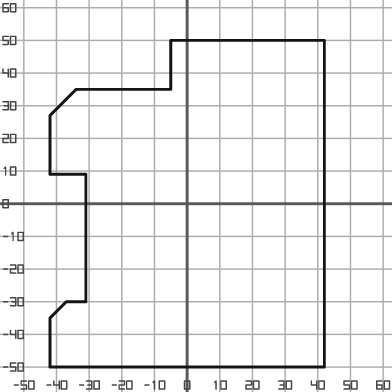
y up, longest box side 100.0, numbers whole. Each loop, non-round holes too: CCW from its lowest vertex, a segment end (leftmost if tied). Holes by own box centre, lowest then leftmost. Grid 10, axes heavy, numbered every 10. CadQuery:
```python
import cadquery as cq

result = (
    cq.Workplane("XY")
    .moveTo(-42.0, -50.0)
    .lineTo(42.0, -50.0)
    .lineTo(42.0, 50.0)
    .lineTo(-5.0, 50.0)
    .lineTo(-5.0, 35.0)
    .lineTo(-34.0, 35.0)
    .lineTo(-42.0, 27.0)
    .lineTo(-42.0, 9.0)
    .lineTo(-31.0, 9.0)
    .lineTo(-31.0, -30.0)
    .lineTo(-37.0, -30.0)
    .lineTo(-42.0, -35.0)
    .close()
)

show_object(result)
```